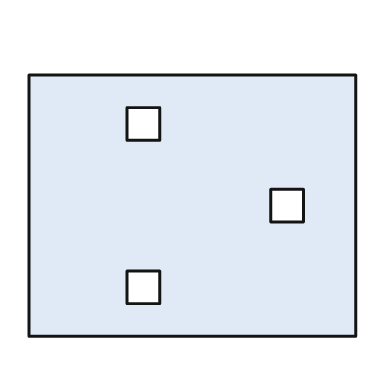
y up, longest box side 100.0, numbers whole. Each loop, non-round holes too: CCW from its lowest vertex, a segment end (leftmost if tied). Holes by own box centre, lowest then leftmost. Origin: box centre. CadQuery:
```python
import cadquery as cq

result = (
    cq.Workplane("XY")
    .moveTo(-50.0, -40.0)
    .lineTo(50.0, -40.0)
    .lineTo(50.0, 40.0)
    .lineTo(-50.0, 40.0)
    .close()
    .moveTo(-20.0, -30.0)
    .lineTo(-10.0, -30.0)
    .lineTo(-10.0, -20.0)
    .lineTo(-20.0, -20.0)
    .close()
    .moveTo(24.0, -5.0)
    .lineTo(34.0, -5.0)
    .lineTo(34.0, 5.0)
    .lineTo(24.0, 5.0)
    .close()
    .moveTo(-20.0, 20.0)
    .lineTo(-10.0, 20.0)
    .lineTo(-10.0, 30.0)
    .lineTo(-20.0, 30.0)
    .close()
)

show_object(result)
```